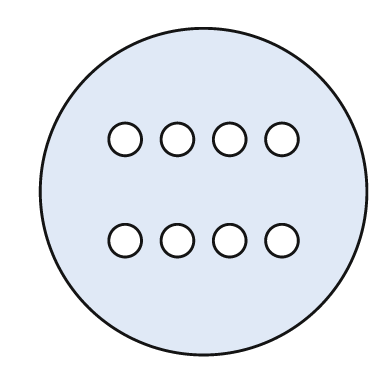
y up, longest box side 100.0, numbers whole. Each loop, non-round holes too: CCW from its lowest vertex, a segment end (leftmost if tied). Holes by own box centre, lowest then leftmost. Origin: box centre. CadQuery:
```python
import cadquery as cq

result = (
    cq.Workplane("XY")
    .moveTo(0.0, 0.0)
    .circle(50.0)
    .moveTo(-24.0, -15.0)
    .circle(5.0)
    .moveTo(-8.0, -15.0)
    .circle(5.0)
    .moveTo(8.0, -15.0)
    .circle(5.0)
    .moveTo(24.0, -15.0)
    .circle(5.0)
    .moveTo(-24.0, 16.0)
    .circle(5.0)
    .moveTo(-8.0, 16.0)
    .circle(5.0)
    .moveTo(8.0, 16.0)
    .circle(5.0)
    .moveTo(24.0, 16.0)
    .circle(5.0)
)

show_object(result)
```